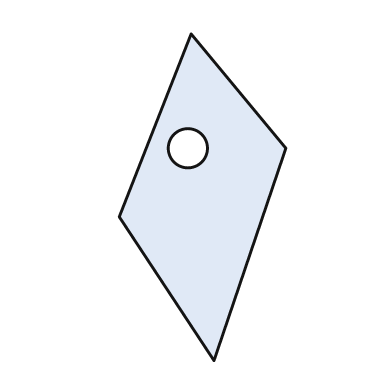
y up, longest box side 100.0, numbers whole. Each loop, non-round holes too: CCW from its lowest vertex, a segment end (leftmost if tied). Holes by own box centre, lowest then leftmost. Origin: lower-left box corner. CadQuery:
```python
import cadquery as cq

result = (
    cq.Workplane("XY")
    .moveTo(29.0, 0.0)
    .lineTo(51.0, 65.0)
    .lineTo(22.0, 100.0)
    .lineTo(0.0, 44.0)
    .close()
    .moveTo(21.0, 65.0)
    .circle(6.0)
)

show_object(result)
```